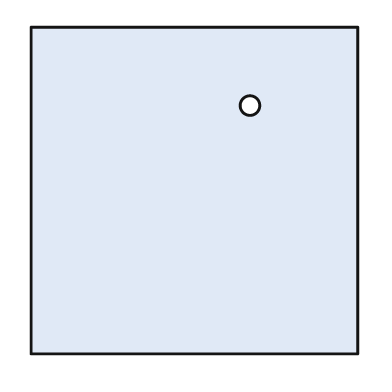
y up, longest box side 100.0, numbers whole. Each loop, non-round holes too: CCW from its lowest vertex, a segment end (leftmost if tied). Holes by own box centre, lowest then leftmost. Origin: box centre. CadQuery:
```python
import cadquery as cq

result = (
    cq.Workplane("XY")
    .moveTo(-50.0, -50.0)
    .lineTo(50.0, -50.0)
    .lineTo(50.0, 50.0)
    .lineTo(-50.0, 50.0)
    .close()
    .moveTo(17.0, 26.0)
    .circle(3.0)
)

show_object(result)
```